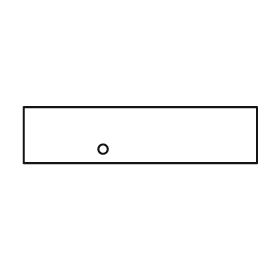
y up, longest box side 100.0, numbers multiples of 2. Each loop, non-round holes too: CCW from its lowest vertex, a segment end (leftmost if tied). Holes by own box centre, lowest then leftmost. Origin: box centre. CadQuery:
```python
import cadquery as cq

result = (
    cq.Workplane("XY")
    .moveTo(-50.0, -12.0)
    .lineTo(50.0, -12.0)
    .lineTo(50.0, 12.0)
    .lineTo(-50.0, 12.0)
    .close()
    .moveTo(-16.0, -6.0)
    .circle(2.0)
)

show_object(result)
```